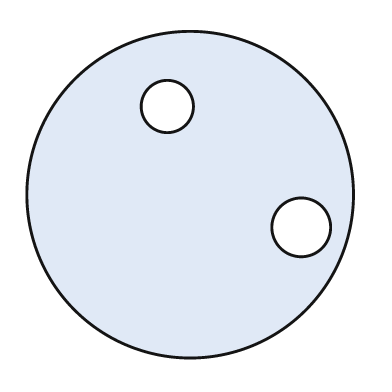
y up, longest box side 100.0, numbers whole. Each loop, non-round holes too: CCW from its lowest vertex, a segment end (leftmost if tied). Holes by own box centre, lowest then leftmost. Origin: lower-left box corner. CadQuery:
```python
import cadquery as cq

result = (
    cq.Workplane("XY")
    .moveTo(50.0, 50.0)
    .circle(50.0)
    .moveTo(84.0, 40.0)
    .circle(9.0)
    .moveTo(43.0, 77.0)
    .circle(8.0)
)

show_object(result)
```